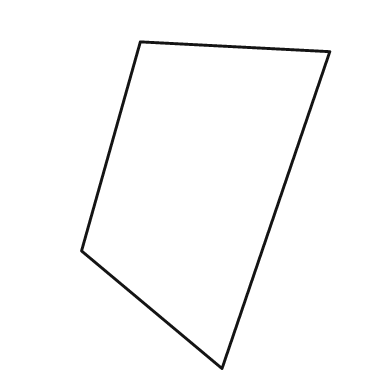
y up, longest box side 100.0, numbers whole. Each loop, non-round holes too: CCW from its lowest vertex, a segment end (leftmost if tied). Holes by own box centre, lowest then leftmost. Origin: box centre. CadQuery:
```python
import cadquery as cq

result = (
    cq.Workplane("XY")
    .moveTo(5.0, -50.0)
    .lineTo(38.0, 47.0)
    .lineTo(-20.0, 50.0)
    .lineTo(-38.0, -14.0)
    .close()
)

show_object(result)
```